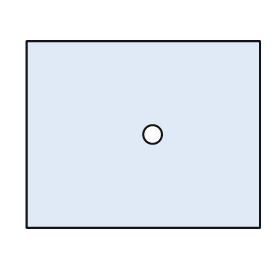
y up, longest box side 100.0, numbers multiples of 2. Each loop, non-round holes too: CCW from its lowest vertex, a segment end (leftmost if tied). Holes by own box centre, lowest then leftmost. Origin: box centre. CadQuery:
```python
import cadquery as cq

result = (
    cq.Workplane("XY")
    .moveTo(-50.0, -40.0)
    .lineTo(50.0, -40.0)
    .lineTo(50.0, 40.0)
    .lineTo(-50.0, 40.0)
    .close()
    .moveTo(4.0, 0.0)
    .circle(4.0)
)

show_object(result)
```